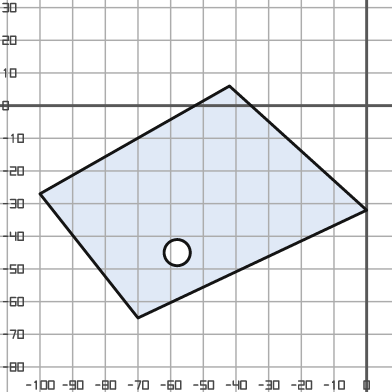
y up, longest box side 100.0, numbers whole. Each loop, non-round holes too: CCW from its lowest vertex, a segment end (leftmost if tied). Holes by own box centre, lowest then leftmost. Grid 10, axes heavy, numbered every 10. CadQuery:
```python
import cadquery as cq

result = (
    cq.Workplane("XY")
    .moveTo(-70.0, -65.0)
    .lineTo(0.0, -32.0)
    .lineTo(-42.0, 6.0)
    .lineTo(-100.0, -27.0)
    .close()
    .moveTo(-58.0, -45.0)
    .circle(4.0)
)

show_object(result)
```